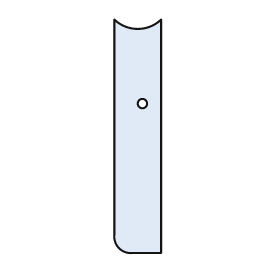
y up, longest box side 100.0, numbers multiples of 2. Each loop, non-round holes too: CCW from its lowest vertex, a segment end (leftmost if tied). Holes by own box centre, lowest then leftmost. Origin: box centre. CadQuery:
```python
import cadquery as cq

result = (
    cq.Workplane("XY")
    .moveTo(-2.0, -50.0)
    .lineTo(10.0, -50.0)
    .lineTo(10.0, 50.0)
    .threePointArc((0.0, 46.0), (-10.0, 50.0))
    .lineTo(-10.0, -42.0)
    .threePointArc((-8.0, -48.0), (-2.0, -50.0))
    .close()
    .moveTo(2.0, 14.0)
    .circle(2.0)
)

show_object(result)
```